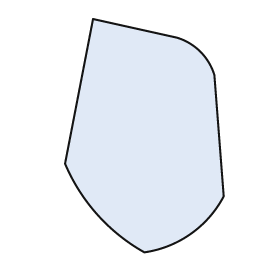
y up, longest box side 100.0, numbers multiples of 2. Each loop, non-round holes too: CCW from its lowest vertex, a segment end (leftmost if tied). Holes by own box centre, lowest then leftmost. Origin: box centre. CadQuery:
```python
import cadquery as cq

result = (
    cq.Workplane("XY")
    .moveTo(0.0, -50.0)
    .threePointArc((20.0, -42.0), (34.0, -26.0))
    .lineTo(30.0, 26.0)
    .threePointArc((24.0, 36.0), (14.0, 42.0))
    .lineTo(-22.0, 50.0)
    .lineTo(-34.0, -12.0)
    .threePointArc((-20.0, -34.0), (0.0, -50.0))
    .close()
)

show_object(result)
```